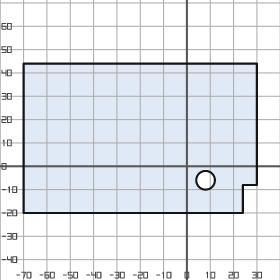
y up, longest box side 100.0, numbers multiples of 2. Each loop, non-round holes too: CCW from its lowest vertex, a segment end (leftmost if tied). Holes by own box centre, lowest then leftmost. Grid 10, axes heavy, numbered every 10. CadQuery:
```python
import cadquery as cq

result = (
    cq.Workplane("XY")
    .moveTo(-70.0, -20.0)
    .lineTo(24.0, -20.0)
    .lineTo(24.0, -8.0)
    .lineTo(30.0, -8.0)
    .lineTo(30.0, 44.0)
    .lineTo(-70.0, 44.0)
    .close()
    .moveTo(8.0, -6.0)
    .circle(4.0)
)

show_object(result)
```